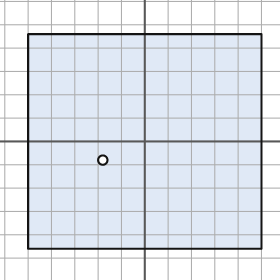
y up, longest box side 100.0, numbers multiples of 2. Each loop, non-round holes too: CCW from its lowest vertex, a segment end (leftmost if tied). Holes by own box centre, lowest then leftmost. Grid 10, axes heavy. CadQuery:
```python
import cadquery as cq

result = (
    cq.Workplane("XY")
    .moveTo(-50.0, -46.0)
    .lineTo(50.0, -46.0)
    .lineTo(50.0, 46.0)
    .lineTo(-50.0, 46.0)
    .close()
    .moveTo(-18.0, -8.0)
    .circle(2.0)
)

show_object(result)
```